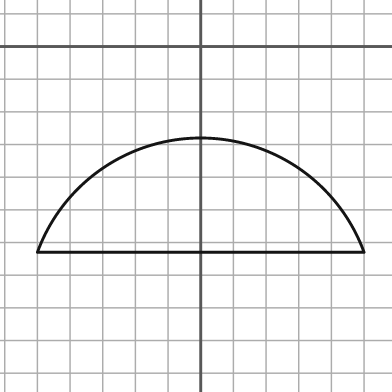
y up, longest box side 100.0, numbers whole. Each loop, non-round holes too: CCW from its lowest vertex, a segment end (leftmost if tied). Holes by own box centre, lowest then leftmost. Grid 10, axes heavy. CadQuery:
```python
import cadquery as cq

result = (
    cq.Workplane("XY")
    .moveTo(-50.0, -63.0)
    .lineTo(50.0, -63.0)
    .threePointArc((0.0, -28.0), (-50.0, -63.0))
    .close()
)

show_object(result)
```